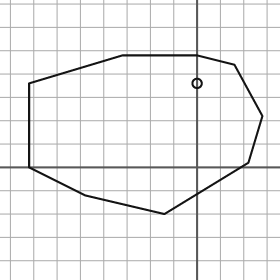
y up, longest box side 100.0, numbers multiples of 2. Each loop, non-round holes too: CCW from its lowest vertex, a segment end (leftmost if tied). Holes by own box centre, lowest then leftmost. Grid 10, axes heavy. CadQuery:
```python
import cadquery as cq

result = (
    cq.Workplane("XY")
    .moveTo(-14.0, -20.0)
    .lineTo(22.0, 2.0)
    .lineTo(28.0, 22.0)
    .lineTo(16.0, 44.0)
    .lineTo(0.0, 48.0)
    .lineTo(-32.0, 48.0)
    .lineTo(-72.0, 36.0)
    .lineTo(-72.0, 0.0)
    .lineTo(-48.0, -12.0)
    .close()
    .moveTo(0.0, 36.0)
    .circle(2.0)
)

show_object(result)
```